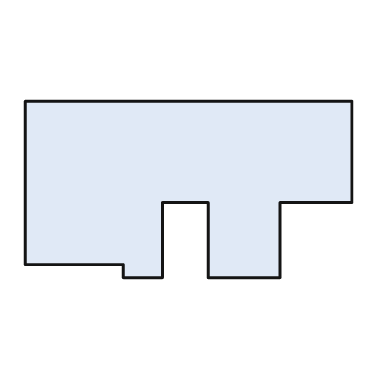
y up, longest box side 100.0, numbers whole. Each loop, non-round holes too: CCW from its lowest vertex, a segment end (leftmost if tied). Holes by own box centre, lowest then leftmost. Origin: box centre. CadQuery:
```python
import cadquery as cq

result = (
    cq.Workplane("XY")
    .moveTo(-20.0, -27.0)
    .lineTo(-8.0, -27.0)
    .lineTo(-8.0, -4.0)
    .lineTo(6.0, -4.0)
    .lineTo(6.0, -27.0)
    .lineTo(28.0, -27.0)
    .lineTo(28.0, -4.0)
    .lineTo(50.0, -4.0)
    .lineTo(50.0, 27.0)
    .lineTo(-50.0, 27.0)
    .lineTo(-50.0, -23.0)
    .lineTo(-20.0, -23.0)
    .close()
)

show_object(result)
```